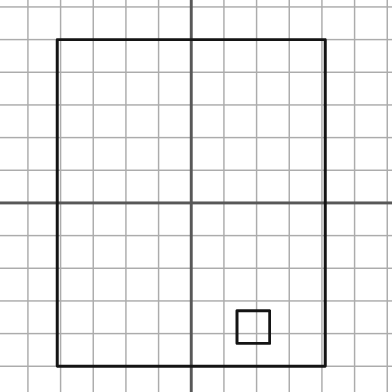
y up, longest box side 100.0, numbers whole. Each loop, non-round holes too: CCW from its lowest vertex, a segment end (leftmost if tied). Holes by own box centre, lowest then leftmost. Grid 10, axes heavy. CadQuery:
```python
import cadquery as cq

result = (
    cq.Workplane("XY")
    .moveTo(-41.0, -50.0)
    .lineTo(41.0, -50.0)
    .lineTo(41.0, 50.0)
    .lineTo(-41.0, 50.0)
    .close()
    .moveTo(14.0, -43.0)
    .lineTo(24.0, -43.0)
    .lineTo(24.0, -33.0)
    .lineTo(14.0, -33.0)
    .close()
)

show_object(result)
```